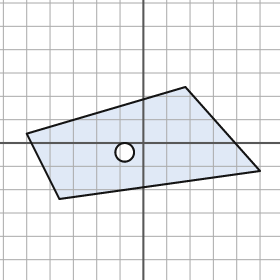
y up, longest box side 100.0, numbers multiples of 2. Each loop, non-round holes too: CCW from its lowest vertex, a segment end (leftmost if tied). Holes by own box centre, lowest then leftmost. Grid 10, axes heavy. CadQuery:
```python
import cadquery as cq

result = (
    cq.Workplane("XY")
    .moveTo(-36.0, -24.0)
    .lineTo(50.0, -12.0)
    .lineTo(18.0, 24.0)
    .lineTo(-50.0, 4.0)
    .close()
    .moveTo(-8.0, -4.0)
    .circle(4.0)
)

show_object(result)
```